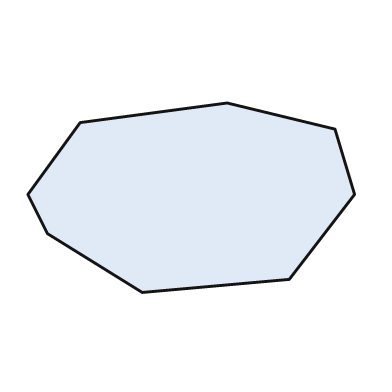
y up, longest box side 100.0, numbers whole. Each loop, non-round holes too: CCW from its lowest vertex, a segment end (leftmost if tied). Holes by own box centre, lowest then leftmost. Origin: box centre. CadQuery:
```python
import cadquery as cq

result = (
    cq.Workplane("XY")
    .moveTo(-15.0, -29.0)
    .lineTo(30.0, -25.0)
    .lineTo(50.0, 1.0)
    .lineTo(44.0, 21.0)
    .lineTo(11.0, 29.0)
    .lineTo(-34.0, 23.0)
    .lineTo(-50.0, 1.0)
    .lineTo(-44.0, -11.0)
    .close()
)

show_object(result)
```